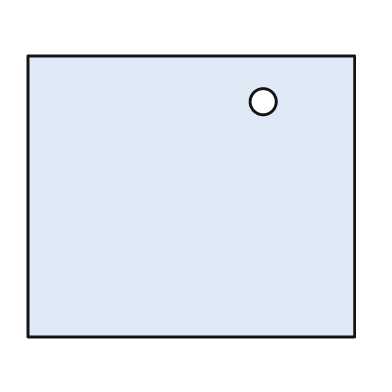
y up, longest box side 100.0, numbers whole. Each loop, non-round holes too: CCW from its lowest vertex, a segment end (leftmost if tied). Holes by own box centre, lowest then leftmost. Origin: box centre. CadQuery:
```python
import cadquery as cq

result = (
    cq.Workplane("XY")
    .moveTo(-50.0, -43.0)
    .lineTo(50.0, -43.0)
    .lineTo(50.0, 43.0)
    .lineTo(-50.0, 43.0)
    .close()
    .moveTo(22.0, 29.0)
    .circle(4.0)
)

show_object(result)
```